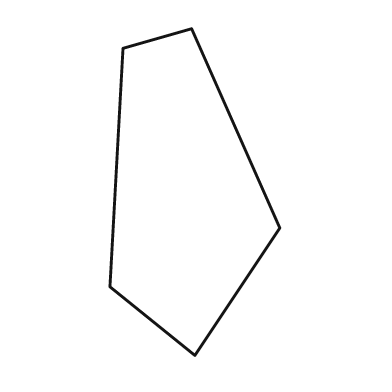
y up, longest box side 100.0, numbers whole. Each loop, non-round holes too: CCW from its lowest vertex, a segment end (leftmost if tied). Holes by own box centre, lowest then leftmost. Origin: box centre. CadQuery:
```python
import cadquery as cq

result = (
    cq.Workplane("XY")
    .moveTo(0.0, -50.0)
    .lineTo(26.0, -11.0)
    .lineTo(-1.0, 50.0)
    .lineTo(-22.0, 44.0)
    .lineTo(-26.0, -29.0)
    .close()
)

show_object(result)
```